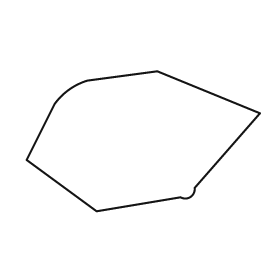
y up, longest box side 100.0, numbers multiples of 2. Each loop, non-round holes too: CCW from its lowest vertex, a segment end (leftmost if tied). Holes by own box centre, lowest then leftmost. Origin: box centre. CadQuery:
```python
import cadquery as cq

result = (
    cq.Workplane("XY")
    .moveTo(-20.0, -30.0)
    .lineTo(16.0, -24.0)
    .threePointArc((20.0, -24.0), (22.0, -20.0))
    .lineTo(50.0, 12.0)
    .lineTo(6.0, 30.0)
    .lineTo(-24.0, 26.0)
    .threePointArc((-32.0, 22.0), (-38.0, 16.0))
    .lineTo(-50.0, -8.0)
    .close()
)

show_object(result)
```